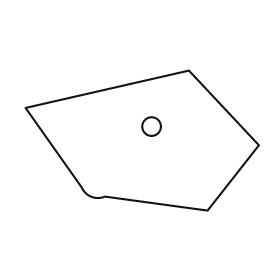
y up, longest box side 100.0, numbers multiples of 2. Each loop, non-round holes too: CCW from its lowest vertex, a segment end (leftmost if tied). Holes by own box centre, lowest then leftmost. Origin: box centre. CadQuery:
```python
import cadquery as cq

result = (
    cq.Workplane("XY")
    .moveTo(28.0, -30.0)
    .lineTo(50.0, -2.0)
    .lineTo(20.0, 30.0)
    .lineTo(-50.0, 14.0)
    .lineTo(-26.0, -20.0)
    .threePointArc((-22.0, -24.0), (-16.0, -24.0))
    .close()
    .moveTo(4.0, 6.0)
    .circle(4.0)
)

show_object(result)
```